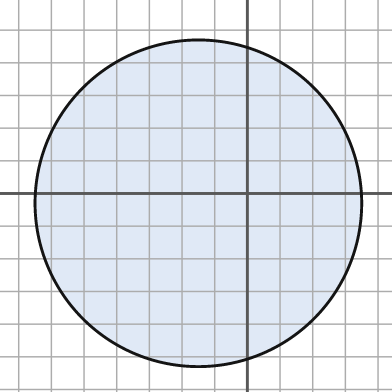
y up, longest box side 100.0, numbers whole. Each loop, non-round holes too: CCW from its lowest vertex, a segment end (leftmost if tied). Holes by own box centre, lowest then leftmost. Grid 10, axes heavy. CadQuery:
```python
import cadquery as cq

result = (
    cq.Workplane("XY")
    .moveTo(-15.0, -3.0)
    .circle(50.0)
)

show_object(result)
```